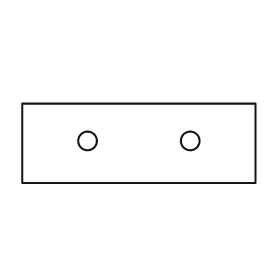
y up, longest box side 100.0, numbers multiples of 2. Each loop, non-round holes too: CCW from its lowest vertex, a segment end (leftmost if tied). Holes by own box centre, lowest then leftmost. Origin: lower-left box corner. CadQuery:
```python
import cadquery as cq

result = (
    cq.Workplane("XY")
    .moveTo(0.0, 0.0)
    .lineTo(100.0, 0.0)
    .lineTo(100.0, 34.0)
    .lineTo(0.0, 34.0)
    .close()
    .moveTo(28.0, 18.0)
    .circle(4.0)
    .moveTo(72.0, 18.0)
    .circle(4.0)
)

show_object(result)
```